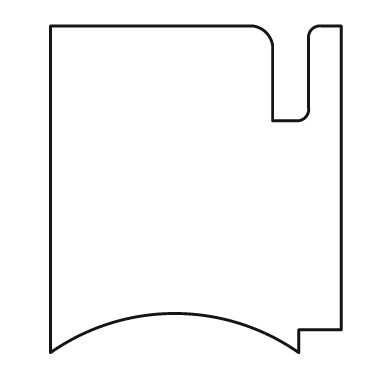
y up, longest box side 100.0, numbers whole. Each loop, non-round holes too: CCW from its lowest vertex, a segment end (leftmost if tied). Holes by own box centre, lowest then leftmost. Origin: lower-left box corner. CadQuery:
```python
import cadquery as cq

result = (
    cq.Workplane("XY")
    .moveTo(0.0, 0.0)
    .threePointArc((38.0, 12.0), (76.0, 0.0))
    .lineTo(76.0, 7.0)
    .lineTo(89.0, 7.0)
    .lineTo(89.0, 100.0)
    .lineTo(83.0, 100.0)
    .threePointArc((80.0, 99.0), (79.0, 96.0))
    .lineTo(79.0, 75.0)
    .threePointArc((78.0, 72.0), (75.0, 71.0))
    .lineTo(68.0, 71.0)
    .lineTo(68.0, 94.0)
    .threePointArc((66.0, 98.0), (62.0, 100.0))
    .lineTo(0.0, 100.0)
    .close()
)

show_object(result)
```